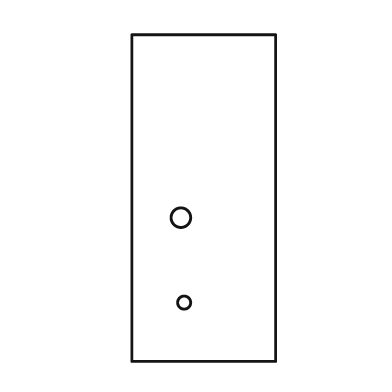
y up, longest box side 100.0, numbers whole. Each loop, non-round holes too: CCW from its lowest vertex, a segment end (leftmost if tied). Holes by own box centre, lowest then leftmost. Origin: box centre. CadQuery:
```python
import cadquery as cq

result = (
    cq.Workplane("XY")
    .moveTo(-22.0, -50.0)
    .lineTo(22.0, -50.0)
    .lineTo(22.0, 50.0)
    .lineTo(-22.0, 50.0)
    .close()
    .moveTo(-6.0, -32.0)
    .circle(2.0)
    .moveTo(-7.0, -6.0)
    .circle(3.0)
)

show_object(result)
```